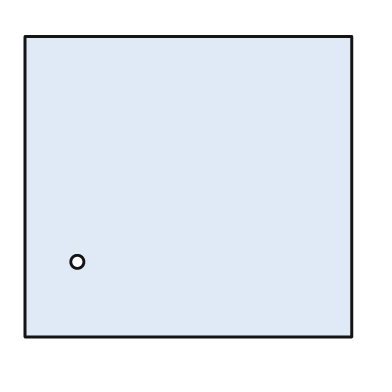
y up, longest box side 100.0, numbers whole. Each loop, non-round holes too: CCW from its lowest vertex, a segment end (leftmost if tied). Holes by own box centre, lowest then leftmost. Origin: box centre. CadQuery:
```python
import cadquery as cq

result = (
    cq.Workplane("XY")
    .moveTo(-50.0, -46.0)
    .lineTo(50.0, -46.0)
    .lineTo(50.0, 46.0)
    .lineTo(-50.0, 46.0)
    .close()
    .moveTo(-34.0, -23.0)
    .circle(2.0)
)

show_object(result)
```